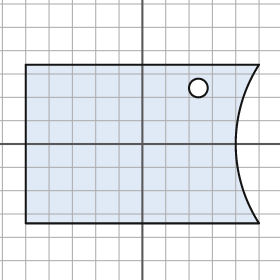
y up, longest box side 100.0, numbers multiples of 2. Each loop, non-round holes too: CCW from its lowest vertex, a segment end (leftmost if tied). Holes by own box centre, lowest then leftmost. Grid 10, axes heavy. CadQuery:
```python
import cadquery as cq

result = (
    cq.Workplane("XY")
    .moveTo(-50.0, -34.0)
    .lineTo(50.0, -34.0)
    .threePointArc((40.0, 0.0), (50.0, 34.0))
    .lineTo(-50.0, 34.0)
    .close()
    .moveTo(24.0, 24.0)
    .circle(4.0)
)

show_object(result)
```